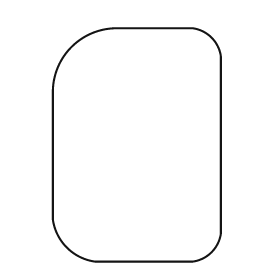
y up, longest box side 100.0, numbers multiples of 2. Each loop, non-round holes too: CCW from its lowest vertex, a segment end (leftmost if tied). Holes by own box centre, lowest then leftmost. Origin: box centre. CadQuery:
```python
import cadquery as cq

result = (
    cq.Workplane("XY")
    .moveTo(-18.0, -50.0)
    .lineTo(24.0, -50.0)
    .threePointArc((32.0, -46.0), (36.0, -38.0))
    .lineTo(36.0, 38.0)
    .threePointArc((32.0, 46.0), (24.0, 50.0))
    .lineTo(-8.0, 50.0)
    .threePointArc((-28.0, 42.0), (-36.0, 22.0))
    .lineTo(-36.0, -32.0)
    .threePointArc((-30.0, -44.0), (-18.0, -50.0))
    .close()
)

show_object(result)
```